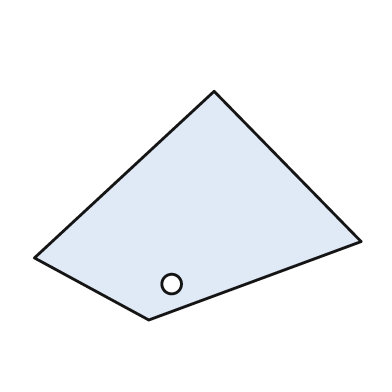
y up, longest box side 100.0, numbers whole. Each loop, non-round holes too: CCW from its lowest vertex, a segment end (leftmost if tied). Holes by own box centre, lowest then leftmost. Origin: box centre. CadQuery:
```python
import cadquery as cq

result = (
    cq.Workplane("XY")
    .moveTo(-15.0, -35.0)
    .lineTo(50.0, -11.0)
    .lineTo(5.0, 35.0)
    .lineTo(-50.0, -16.0)
    .close()
    .moveTo(-8.0, -24.0)
    .circle(3.0)
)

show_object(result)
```